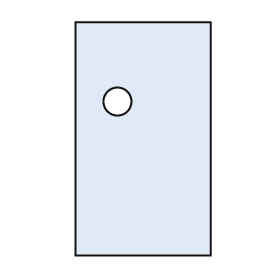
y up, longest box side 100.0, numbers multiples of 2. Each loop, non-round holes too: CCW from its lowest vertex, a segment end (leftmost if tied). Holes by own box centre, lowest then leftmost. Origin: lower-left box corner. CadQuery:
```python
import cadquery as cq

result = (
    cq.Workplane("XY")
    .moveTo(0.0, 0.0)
    .lineTo(58.0, 0.0)
    .lineTo(58.0, 100.0)
    .lineTo(0.0, 100.0)
    .close()
    .moveTo(18.0, 66.0)
    .circle(6.0)
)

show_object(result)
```